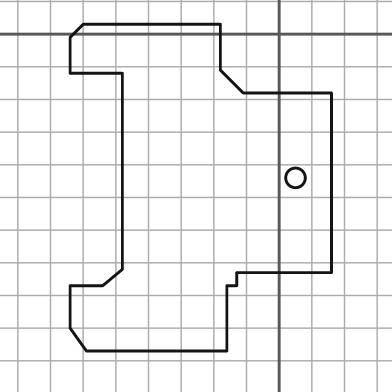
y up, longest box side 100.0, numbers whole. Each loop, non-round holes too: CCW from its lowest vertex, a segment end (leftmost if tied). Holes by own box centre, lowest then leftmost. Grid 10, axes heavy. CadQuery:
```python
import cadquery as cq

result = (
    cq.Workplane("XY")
    .moveTo(-59.0, -97.0)
    .lineTo(-16.0, -97.0)
    .lineTo(-16.0, -77.0)
    .lineTo(-13.0, -77.0)
    .lineTo(-13.0, -73.0)
    .lineTo(16.0, -73.0)
    .lineTo(16.0, -18.0)
    .lineTo(-11.0, -18.0)
    .lineTo(-18.0, -11.0)
    .lineTo(-18.0, 3.0)
    .lineTo(-60.0, 3.0)
    .lineTo(-64.0, -1.0)
    .lineTo(-64.0, -12.0)
    .lineTo(-48.0, -12.0)
    .lineTo(-48.0, -72.0)
    .lineTo(-54.0, -77.0)
    .lineTo(-64.0, -77.0)
    .lineTo(-64.0, -90.0)
    .close()
    .moveTo(5.0, -44.0)
    .circle(3.0)
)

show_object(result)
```